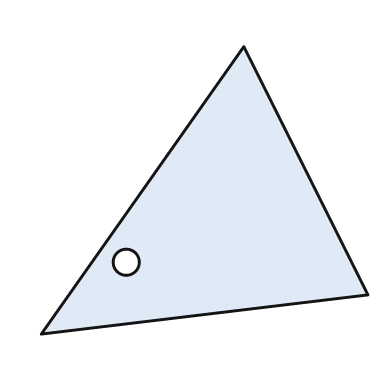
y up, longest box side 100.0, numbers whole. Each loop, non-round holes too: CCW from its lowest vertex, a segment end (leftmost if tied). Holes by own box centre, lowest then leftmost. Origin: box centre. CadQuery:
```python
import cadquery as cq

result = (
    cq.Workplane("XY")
    .moveTo(-50.0, -44.0)
    .lineTo(50.0, -32.0)
    .lineTo(12.0, 44.0)
    .close()
    .moveTo(-24.0, -22.0)
    .circle(4.0)
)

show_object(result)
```